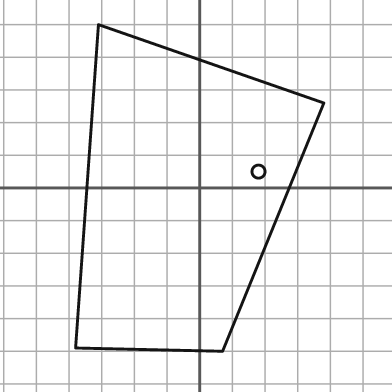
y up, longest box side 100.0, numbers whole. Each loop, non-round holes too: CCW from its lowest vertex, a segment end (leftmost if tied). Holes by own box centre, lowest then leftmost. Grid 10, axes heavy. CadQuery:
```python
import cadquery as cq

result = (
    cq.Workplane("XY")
    .moveTo(7.0, -50.0)
    .lineTo(38.0, 26.0)
    .lineTo(-31.0, 50.0)
    .lineTo(-38.0, -49.0)
    .close()
    .moveTo(18.0, 5.0)
    .circle(2.0)
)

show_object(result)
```